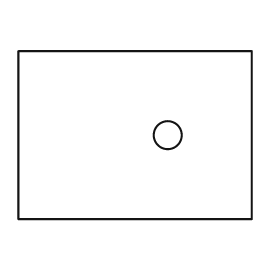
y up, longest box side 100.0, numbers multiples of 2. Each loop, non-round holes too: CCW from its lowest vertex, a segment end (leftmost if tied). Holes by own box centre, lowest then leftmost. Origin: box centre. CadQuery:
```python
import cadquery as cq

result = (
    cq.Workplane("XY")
    .moveTo(-50.0, -36.0)
    .lineTo(50.0, -36.0)
    .lineTo(50.0, 36.0)
    .lineTo(-50.0, 36.0)
    .close()
    .moveTo(14.0, 0.0)
    .circle(6.0)
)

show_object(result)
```